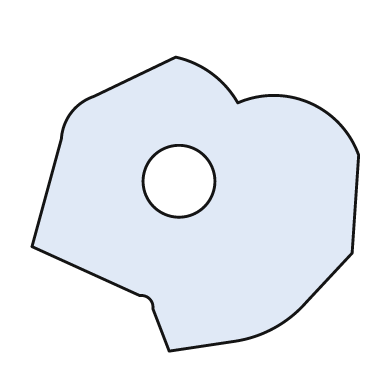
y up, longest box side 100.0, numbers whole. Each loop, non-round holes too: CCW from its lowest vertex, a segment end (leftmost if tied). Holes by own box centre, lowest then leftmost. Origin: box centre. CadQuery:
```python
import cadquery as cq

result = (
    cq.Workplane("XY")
    .moveTo(-8.0, -45.0)
    .lineTo(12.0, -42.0)
    .threePointArc((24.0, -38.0), (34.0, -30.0))
    .lineTo(48.0, -15.0)
    .lineTo(50.0, 15.0)
    .threePointArc((35.0, 31.0), (13.0, 31.0))
    .threePointArc((5.0, 40.0), (-6.0, 45.0))
    .lineTo(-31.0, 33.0)
    .threePointArc((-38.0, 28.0), (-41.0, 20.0))
    .lineTo(-50.0, -13.0)
    .lineTo(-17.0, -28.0)
    .threePointArc((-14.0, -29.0), (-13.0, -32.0))
    .close()
    .moveTo(-5.0, 7.0)
    .circle(11.0)
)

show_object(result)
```